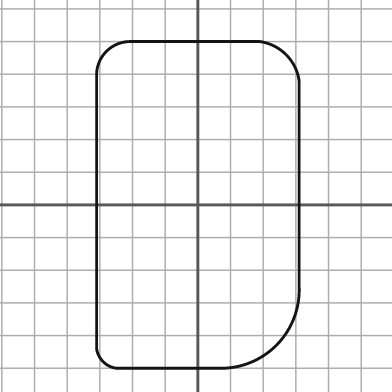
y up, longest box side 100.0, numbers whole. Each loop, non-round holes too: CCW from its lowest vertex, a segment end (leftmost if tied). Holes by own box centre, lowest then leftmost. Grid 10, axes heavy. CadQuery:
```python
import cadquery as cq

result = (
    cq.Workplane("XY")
    .moveTo(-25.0, -50.0)
    .lineTo(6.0, -50.0)
    .threePointArc((24.0, -43.0), (31.0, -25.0))
    .lineTo(31.0, 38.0)
    .threePointArc((27.0, 46.0), (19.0, 50.0))
    .lineTo(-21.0, 50.0)
    .threePointArc((-28.0, 47.0), (-31.0, 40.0))
    .lineTo(-31.0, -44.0)
    .threePointArc((-29.0, -48.0), (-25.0, -50.0))
    .close()
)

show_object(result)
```